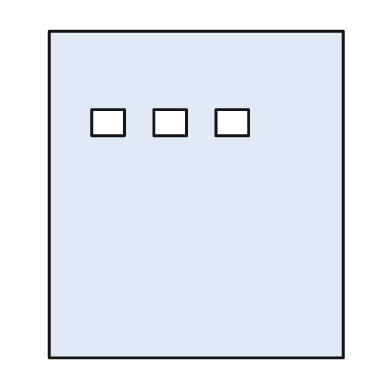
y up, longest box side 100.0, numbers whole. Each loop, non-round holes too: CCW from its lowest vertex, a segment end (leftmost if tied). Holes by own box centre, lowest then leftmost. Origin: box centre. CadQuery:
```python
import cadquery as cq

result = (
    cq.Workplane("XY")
    .moveTo(-45.0, -50.0)
    .lineTo(45.0, -50.0)
    .lineTo(45.0, 50.0)
    .lineTo(-45.0, 50.0)
    .close()
    .moveTo(-32.0, 18.0)
    .lineTo(-22.0, 18.0)
    .lineTo(-22.0, 26.0)
    .lineTo(-32.0, 26.0)
    .close()
    .moveTo(-13.0, 18.0)
    .lineTo(-3.0, 18.0)
    .lineTo(-3.0, 26.0)
    .lineTo(-13.0, 26.0)
    .close()
    .moveTo(6.0, 18.0)
    .lineTo(16.0, 18.0)
    .lineTo(16.0, 26.0)
    .lineTo(6.0, 26.0)
    .close()
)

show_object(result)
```